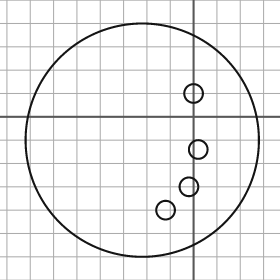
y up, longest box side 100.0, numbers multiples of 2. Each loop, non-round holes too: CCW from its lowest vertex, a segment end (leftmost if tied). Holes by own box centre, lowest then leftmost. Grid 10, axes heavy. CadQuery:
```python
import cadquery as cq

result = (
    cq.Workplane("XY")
    .moveTo(-22.0, -10.0)
    .circle(50.0)
    .moveTo(-12.0, -40.0)
    .circle(4.0)
    .moveTo(-2.0, -30.0)
    .circle(4.0)
    .moveTo(2.0, -14.0)
    .circle(4.0)
    .moveTo(0.0, 10.0)
    .circle(4.0)
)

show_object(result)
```